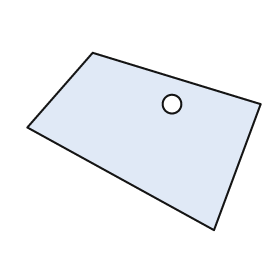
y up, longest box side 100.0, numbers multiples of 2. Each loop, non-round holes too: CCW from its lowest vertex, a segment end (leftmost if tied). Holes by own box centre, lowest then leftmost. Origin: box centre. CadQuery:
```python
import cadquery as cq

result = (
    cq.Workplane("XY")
    .moveTo(30.0, -38.0)
    .lineTo(50.0, 16.0)
    .lineTo(-22.0, 38.0)
    .lineTo(-50.0, 6.0)
    .close()
    .moveTo(12.0, 16.0)
    .circle(4.0)
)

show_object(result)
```